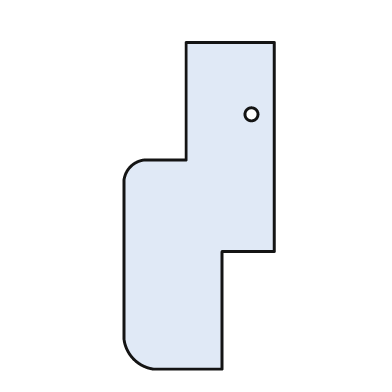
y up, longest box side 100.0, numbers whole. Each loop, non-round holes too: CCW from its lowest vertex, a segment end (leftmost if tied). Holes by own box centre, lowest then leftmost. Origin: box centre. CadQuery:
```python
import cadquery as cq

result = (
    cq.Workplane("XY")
    .moveTo(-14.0, -50.0)
    .lineTo(7.0, -50.0)
    .lineTo(7.0, -14.0)
    .lineTo(23.0, -14.0)
    .lineTo(23.0, 50.0)
    .lineTo(-4.0, 50.0)
    .lineTo(-4.0, 14.0)
    .lineTo(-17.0, 14.0)
    .threePointArc((-21.0, 12.0), (-23.0, 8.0))
    .lineTo(-23.0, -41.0)
    .threePointArc((-20.0, -47.0), (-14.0, -50.0))
    .close()
    .moveTo(16.0, 28.0)
    .circle(2.0)
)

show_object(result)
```